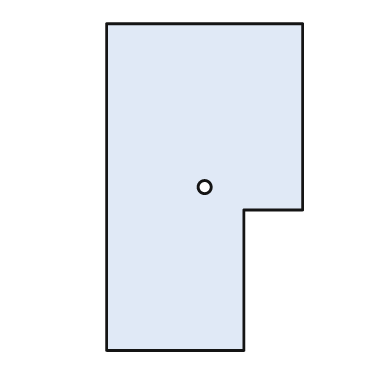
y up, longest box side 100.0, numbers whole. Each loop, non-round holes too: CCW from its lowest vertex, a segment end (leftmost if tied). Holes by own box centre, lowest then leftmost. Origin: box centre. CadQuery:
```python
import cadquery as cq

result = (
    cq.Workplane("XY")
    .moveTo(-30.0, -50.0)
    .lineTo(12.0, -50.0)
    .lineTo(12.0, -7.0)
    .lineTo(30.0, -7.0)
    .lineTo(30.0, 50.0)
    .lineTo(-30.0, 50.0)
    .close()
    .moveTo(0.0, 0.0)
    .circle(2.0)
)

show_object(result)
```